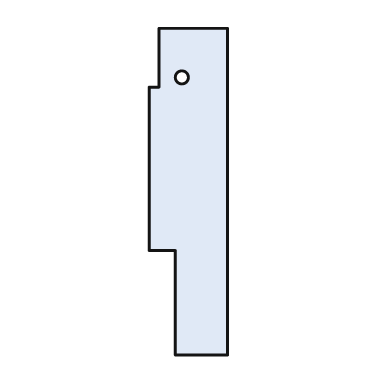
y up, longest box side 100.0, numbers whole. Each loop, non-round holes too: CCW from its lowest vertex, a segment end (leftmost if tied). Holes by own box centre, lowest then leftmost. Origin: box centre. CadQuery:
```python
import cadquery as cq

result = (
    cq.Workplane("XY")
    .moveTo(-4.0, -50.0)
    .lineTo(12.0, -50.0)
    .lineTo(12.0, 50.0)
    .lineTo(-9.0, 50.0)
    .lineTo(-9.0, 32.0)
    .lineTo(-12.0, 32.0)
    .lineTo(-12.0, -18.0)
    .lineTo(-4.0, -18.0)
    .close()
    .moveTo(-2.0, 35.0)
    .circle(2.0)
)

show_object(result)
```